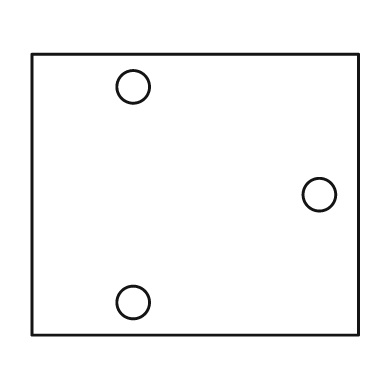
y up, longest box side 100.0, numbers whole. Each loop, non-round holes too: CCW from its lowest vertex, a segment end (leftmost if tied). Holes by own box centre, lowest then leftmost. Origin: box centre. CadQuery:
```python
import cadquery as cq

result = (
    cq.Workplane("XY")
    .moveTo(-50.0, -43.0)
    .lineTo(50.0, -43.0)
    .lineTo(50.0, 43.0)
    .lineTo(-50.0, 43.0)
    .close()
    .moveTo(-19.0, -33.0)
    .circle(5.0)
    .moveTo(38.0, 0.0)
    .circle(5.0)
    .moveTo(-19.0, 33.0)
    .circle(5.0)
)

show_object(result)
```